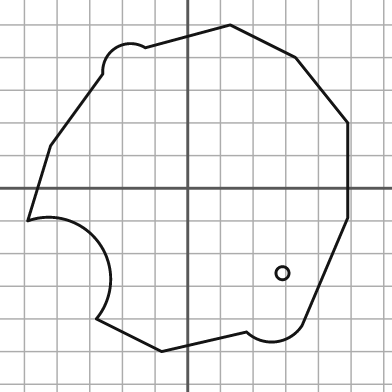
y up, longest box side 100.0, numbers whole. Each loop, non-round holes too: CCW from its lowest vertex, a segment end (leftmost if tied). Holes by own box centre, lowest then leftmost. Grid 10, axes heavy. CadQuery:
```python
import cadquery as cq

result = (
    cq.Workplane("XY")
    .moveTo(-8.0, -50.0)
    .lineTo(18.0, -44.0)
    .threePointArc((27.0, -47.0), (35.0, -42.0))
    .lineTo(49.0, -9.0)
    .lineTo(49.0, 20.0)
    .lineTo(33.0, 40.0)
    .lineTo(13.0, 50.0)
    .lineTo(-13.0, 43.0)
    .threePointArc((-22.0, 43.0), (-26.0, 35.0))
    .lineTo(-42.0, 13.0)
    .lineTo(-49.0, -10.0)
    .threePointArc((-27.0, -17.0), (-28.0, -40.0))
    .close()
    .moveTo(29.0, -26.0)
    .circle(2.0)
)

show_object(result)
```